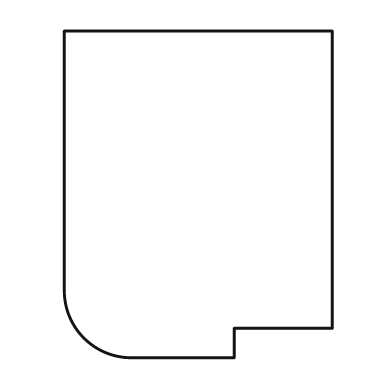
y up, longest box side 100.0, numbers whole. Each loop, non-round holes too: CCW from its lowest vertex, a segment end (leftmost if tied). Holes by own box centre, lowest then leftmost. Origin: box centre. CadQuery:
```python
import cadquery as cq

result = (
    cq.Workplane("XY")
    .moveTo(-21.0, -50.0)
    .lineTo(11.0, -50.0)
    .lineTo(11.0, -41.0)
    .lineTo(41.0, -41.0)
    .lineTo(41.0, 50.0)
    .lineTo(-41.0, 50.0)
    .lineTo(-41.0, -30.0)
    .threePointArc((-35.0, -44.0), (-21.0, -50.0))
    .close()
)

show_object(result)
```